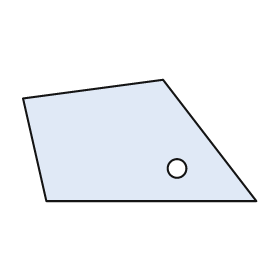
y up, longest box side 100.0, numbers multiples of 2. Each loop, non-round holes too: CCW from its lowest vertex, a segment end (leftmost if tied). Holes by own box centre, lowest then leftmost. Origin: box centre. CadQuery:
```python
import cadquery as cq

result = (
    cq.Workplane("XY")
    .moveTo(-40.0, -26.0)
    .lineTo(50.0, -26.0)
    .lineTo(10.0, 26.0)
    .lineTo(-50.0, 18.0)
    .close()
    .moveTo(16.0, -12.0)
    .circle(4.0)
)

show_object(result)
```